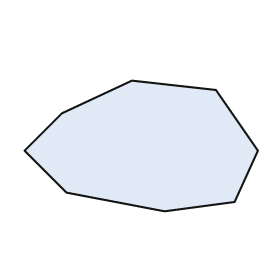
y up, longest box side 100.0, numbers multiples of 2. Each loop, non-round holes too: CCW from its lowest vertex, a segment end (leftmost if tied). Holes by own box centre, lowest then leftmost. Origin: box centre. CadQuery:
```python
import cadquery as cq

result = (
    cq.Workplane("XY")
    .moveTo(10.0, -28.0)
    .lineTo(40.0, -24.0)
    .lineTo(50.0, -2.0)
    .lineTo(32.0, 24.0)
    .lineTo(-4.0, 28.0)
    .lineTo(-34.0, 14.0)
    .lineTo(-50.0, -2.0)
    .lineTo(-32.0, -20.0)
    .close()
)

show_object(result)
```